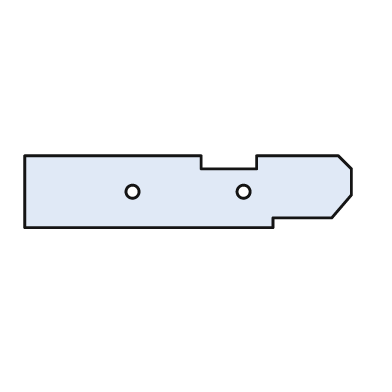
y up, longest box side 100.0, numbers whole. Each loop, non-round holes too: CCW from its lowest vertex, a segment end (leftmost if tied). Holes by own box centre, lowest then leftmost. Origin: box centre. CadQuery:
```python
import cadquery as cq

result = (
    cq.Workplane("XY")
    .moveTo(-50.0, -11.0)
    .lineTo(26.0, -11.0)
    .lineTo(26.0, -8.0)
    .lineTo(44.0, -8.0)
    .lineTo(50.0, -1.0)
    .lineTo(50.0, 7.0)
    .lineTo(46.0, 11.0)
    .lineTo(21.0, 11.0)
    .lineTo(21.0, 7.0)
    .lineTo(4.0, 7.0)
    .lineTo(4.0, 11.0)
    .lineTo(-50.0, 11.0)
    .close()
    .moveTo(-17.0, 0.0)
    .circle(2.0)
    .moveTo(17.0, 0.0)
    .circle(2.0)
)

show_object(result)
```